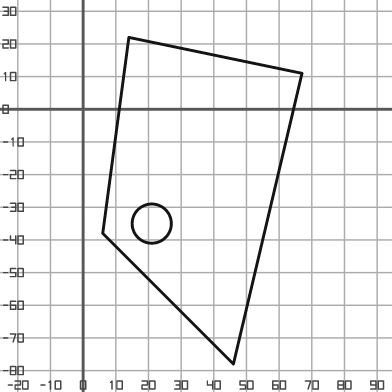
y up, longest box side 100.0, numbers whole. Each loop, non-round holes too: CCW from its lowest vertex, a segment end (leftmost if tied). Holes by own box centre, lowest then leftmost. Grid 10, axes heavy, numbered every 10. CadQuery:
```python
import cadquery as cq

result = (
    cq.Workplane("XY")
    .moveTo(46.0, -78.0)
    .lineTo(67.0, 11.0)
    .lineTo(14.0, 22.0)
    .lineTo(6.0, -38.0)
    .close()
    .moveTo(21.0, -35.0)
    .circle(6.0)
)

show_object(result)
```